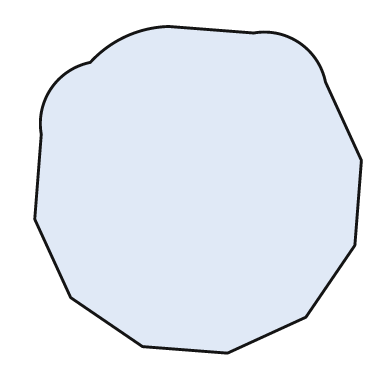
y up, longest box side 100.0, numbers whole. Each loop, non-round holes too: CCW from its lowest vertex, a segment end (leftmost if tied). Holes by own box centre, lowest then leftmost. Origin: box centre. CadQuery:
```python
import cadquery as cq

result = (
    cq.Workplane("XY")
    .moveTo(9.0, -50.0)
    .lineTo(33.0, -39.0)
    .lineTo(48.0, -17.0)
    .lineTo(50.0, 9.0)
    .lineTo(39.0, 33.0)
    .threePointArc((31.0, 45.0), (17.0, 48.0))
    .lineTo(-9.0, 50.0)
    .threePointArc((-22.0, 47.0), (-33.0, 39.0))
    .threePointArc((-45.0, 31.0), (-48.0, 17.0))
    .lineTo(-50.0, -9.0)
    .lineTo(-39.0, -33.0)
    .lineTo(-17.0, -48.0)
    .close()
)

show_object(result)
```